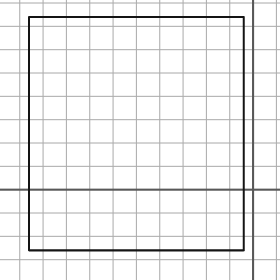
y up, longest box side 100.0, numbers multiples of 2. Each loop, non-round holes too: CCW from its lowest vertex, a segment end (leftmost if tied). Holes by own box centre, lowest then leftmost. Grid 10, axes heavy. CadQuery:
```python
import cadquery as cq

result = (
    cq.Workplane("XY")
    .moveTo(-96.0, -26.0)
    .lineTo(-4.0, -26.0)
    .lineTo(-4.0, 74.0)
    .lineTo(-96.0, 74.0)
    .close()
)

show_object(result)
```